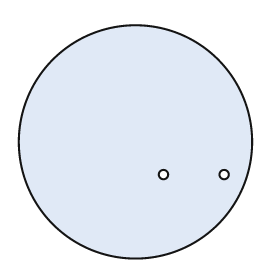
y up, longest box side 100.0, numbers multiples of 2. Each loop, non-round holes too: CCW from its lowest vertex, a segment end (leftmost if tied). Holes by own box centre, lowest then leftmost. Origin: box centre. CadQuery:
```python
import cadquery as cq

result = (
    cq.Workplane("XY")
    .moveTo(0.0, 0.0)
    .circle(50.0)
    .moveTo(12.0, -14.0)
    .circle(2.0)
    .moveTo(38.0, -14.0)
    .circle(2.0)
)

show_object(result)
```